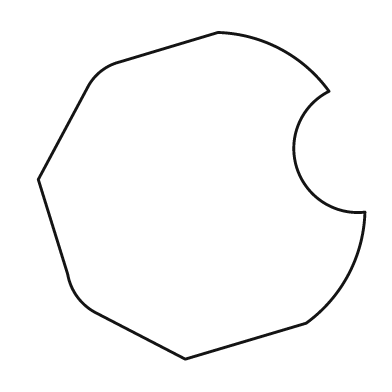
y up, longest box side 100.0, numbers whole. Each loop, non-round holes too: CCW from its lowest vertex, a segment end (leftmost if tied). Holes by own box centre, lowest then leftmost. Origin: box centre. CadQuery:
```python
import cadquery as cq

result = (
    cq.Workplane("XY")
    .moveTo(-5.0, -50.0)
    .lineTo(32.0, -39.0)
    .threePointArc((45.0, -24.0), (50.0, -5.0))
    .threePointArc((29.0, 9.0), (39.0, 32.0))
    .threePointArc((24.0, 45.0), (5.0, 50.0))
    .lineTo(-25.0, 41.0)
    .threePointArc((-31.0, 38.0), (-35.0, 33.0))
    .lineTo(-50.0, 5.0)
    .lineTo(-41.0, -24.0)
    .threePointArc((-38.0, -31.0), (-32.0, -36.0))
    .close()
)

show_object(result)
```